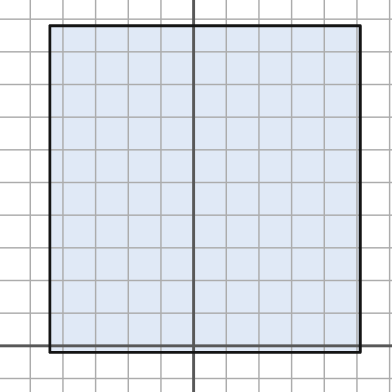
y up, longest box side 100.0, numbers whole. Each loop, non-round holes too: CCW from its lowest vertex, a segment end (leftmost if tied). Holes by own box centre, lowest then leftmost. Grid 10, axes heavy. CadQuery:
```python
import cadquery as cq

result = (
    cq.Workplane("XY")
    .moveTo(-44.0, -2.0)
    .lineTo(51.0, -2.0)
    .lineTo(51.0, 98.0)
    .lineTo(-44.0, 98.0)
    .close()
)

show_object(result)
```